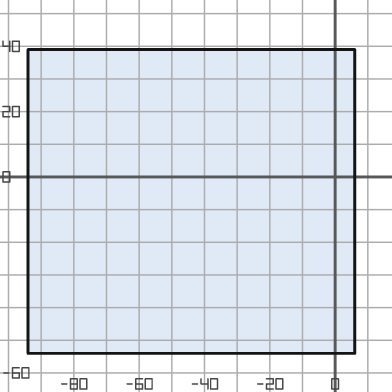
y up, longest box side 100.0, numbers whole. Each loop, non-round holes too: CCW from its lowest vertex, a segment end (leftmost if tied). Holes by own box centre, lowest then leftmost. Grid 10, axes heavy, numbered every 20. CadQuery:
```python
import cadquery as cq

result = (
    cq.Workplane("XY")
    .moveTo(-94.0, -54.0)
    .lineTo(6.0, -54.0)
    .lineTo(6.0, 39.0)
    .lineTo(-94.0, 39.0)
    .close()
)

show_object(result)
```